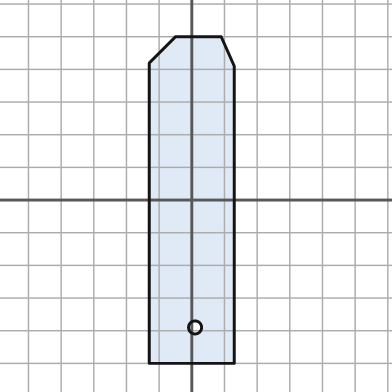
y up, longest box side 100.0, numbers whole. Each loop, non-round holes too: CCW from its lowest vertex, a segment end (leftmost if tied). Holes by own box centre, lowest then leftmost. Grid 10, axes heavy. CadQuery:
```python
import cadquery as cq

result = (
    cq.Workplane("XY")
    .moveTo(-13.0, -50.0)
    .lineTo(13.0, -50.0)
    .lineTo(13.0, 41.0)
    .lineTo(9.0, 50.0)
    .lineTo(-5.0, 50.0)
    .lineTo(-13.0, 42.0)
    .close()
    .moveTo(1.0, -39.0)
    .circle(2.0)
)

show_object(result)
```